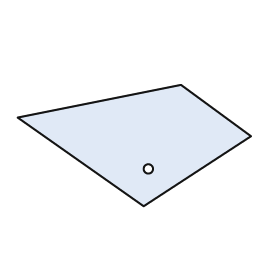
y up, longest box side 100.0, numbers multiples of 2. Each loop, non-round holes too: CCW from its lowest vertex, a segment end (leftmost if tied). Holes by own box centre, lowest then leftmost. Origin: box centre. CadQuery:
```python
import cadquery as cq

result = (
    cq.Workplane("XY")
    .moveTo(4.0, -26.0)
    .lineTo(50.0, 4.0)
    .lineTo(20.0, 26.0)
    .lineTo(-50.0, 12.0)
    .close()
    .moveTo(6.0, -10.0)
    .circle(2.0)
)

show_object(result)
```